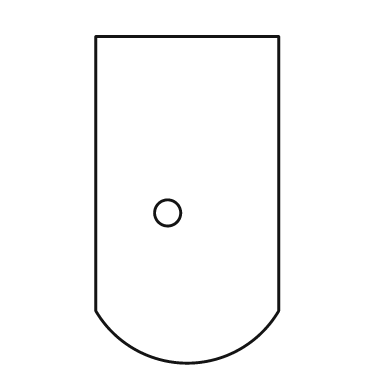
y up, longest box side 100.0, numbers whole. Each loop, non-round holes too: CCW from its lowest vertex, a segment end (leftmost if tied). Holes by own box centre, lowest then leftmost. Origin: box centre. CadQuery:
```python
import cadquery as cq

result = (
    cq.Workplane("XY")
    .moveTo(-28.0, -34.0)
    .threePointArc((0.0, -50.0), (28.0, -34.0))
    .lineTo(28.0, 50.0)
    .lineTo(-28.0, 50.0)
    .close()
    .moveTo(-6.0, -4.0)
    .circle(4.0)
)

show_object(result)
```